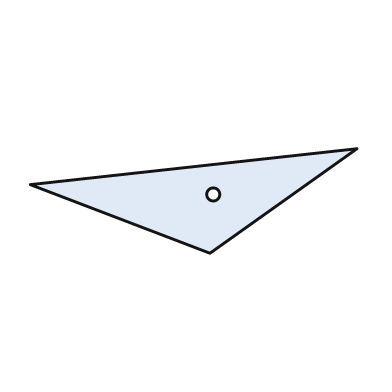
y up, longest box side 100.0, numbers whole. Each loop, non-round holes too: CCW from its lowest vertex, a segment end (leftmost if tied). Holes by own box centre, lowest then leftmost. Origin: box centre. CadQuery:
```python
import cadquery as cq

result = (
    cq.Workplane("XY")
    .moveTo(5.0, -16.0)
    .lineTo(50.0, 16.0)
    .lineTo(-50.0, 5.0)
    .close()
    .moveTo(6.0, 2.0)
    .circle(2.0)
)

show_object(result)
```